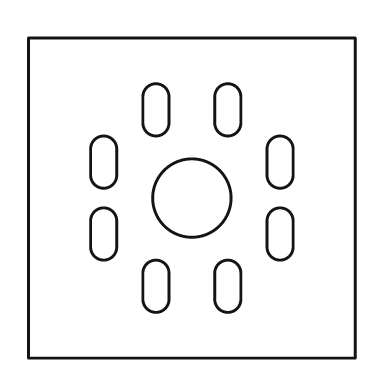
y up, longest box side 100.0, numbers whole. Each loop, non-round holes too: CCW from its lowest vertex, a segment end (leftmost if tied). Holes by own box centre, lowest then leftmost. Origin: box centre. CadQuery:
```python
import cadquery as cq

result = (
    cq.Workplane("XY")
    .moveTo(-50.0, -49.0)
    .lineTo(50.0, -49.0)
    .lineTo(50.0, 49.0)
    .lineTo(-50.0, 49.0)
    .close()
    .moveTo(-15.0, -31.0)
    .threePointArc((-11.0, -35.0), (-7.0, -31.0))
    .lineTo(-7.0, -23.0)
    .threePointArc((-11.0, -19.0), (-15.0, -23.0))
    .close()
    .moveTo(7.0, -31.0)
    .threePointArc((11.0, -35.0), (15.0, -31.0))
    .lineTo(15.0, -23.0)
    .threePointArc((11.0, -19.0), (7.0, -23.0))
    .close()
    .moveTo(-31.0, -15.0)
    .threePointArc((-27.0, -19.0), (-23.0, -15.0))
    .lineTo(-23.0, -7.0)
    .threePointArc((-27.0, -3.0), (-31.0, -7.0))
    .close()
    .moveTo(23.0, -15.0)
    .threePointArc((27.0, -19.0), (31.0, -15.0))
    .lineTo(31.0, -7.0)
    .threePointArc((27.0, -3.0), (23.0, -7.0))
    .close()
    .moveTo(0.0, 0.0)
    .circle(12.0)
    .moveTo(-31.0, 7.0)
    .threePointArc((-27.0, 3.0), (-23.0, 7.0))
    .lineTo(-23.0, 15.0)
    .threePointArc((-27.0, 19.0), (-31.0, 15.0))
    .close()
    .moveTo(23.0, 7.0)
    .threePointArc((27.0, 3.0), (31.0, 7.0))
    .lineTo(31.0, 15.0)
    .threePointArc((27.0, 19.0), (23.0, 15.0))
    .close()
    .moveTo(-15.0, 23.0)
    .threePointArc((-11.0, 19.0), (-7.0, 23.0))
    .lineTo(-7.0, 31.0)
    .threePointArc((-11.0, 35.0), (-15.0, 31.0))
    .close()
    .moveTo(7.0, 23.0)
    .threePointArc((11.0, 19.0), (15.0, 23.0))
    .lineTo(15.0, 31.0)
    .threePointArc((11.0, 35.0), (7.0, 31.0))
    .close()
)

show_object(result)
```